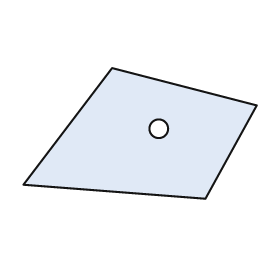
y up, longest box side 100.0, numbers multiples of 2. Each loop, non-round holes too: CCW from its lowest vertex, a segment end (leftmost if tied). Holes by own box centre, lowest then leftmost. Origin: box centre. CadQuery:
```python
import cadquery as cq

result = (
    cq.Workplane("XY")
    .moveTo(28.0, -28.0)
    .lineTo(50.0, 12.0)
    .lineTo(-12.0, 28.0)
    .lineTo(-50.0, -22.0)
    .close()
    .moveTo(8.0, 2.0)
    .circle(4.0)
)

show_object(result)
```